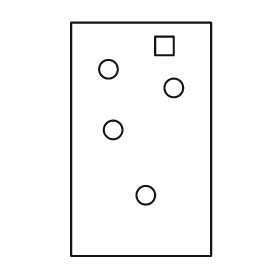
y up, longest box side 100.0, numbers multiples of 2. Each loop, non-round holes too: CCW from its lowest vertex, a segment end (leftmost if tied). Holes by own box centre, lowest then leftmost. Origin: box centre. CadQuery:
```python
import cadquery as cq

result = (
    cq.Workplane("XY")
    .moveTo(-30.0, -50.0)
    .lineTo(30.0, -50.0)
    .lineTo(30.0, 50.0)
    .lineTo(-30.0, 50.0)
    .close()
    .moveTo(2.0, -24.0)
    .circle(4.0)
    .moveTo(-12.0, 4.0)
    .circle(4.0)
    .moveTo(14.0, 22.0)
    .circle(4.0)
    .moveTo(-14.0, 30.0)
    .circle(4.0)
    .moveTo(6.0, 36.0)
    .lineTo(14.0, 36.0)
    .lineTo(14.0, 44.0)
    .lineTo(6.0, 44.0)
    .close()
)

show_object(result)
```